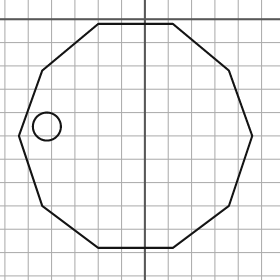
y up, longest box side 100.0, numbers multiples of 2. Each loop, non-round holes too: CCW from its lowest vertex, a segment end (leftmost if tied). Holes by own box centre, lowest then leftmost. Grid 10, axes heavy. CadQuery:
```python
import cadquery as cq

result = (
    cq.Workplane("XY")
    .moveTo(-20.0, -98.0)
    .lineTo(12.0, -98.0)
    .lineTo(36.0, -80.0)
    .lineTo(46.0, -50.0)
    .lineTo(36.0, -22.0)
    .lineTo(12.0, -2.0)
    .lineTo(-20.0, -2.0)
    .lineTo(-44.0, -22.0)
    .lineTo(-54.0, -50.0)
    .lineTo(-44.0, -80.0)
    .close()
    .moveTo(-42.0, -46.0)
    .circle(6.0)
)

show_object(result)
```